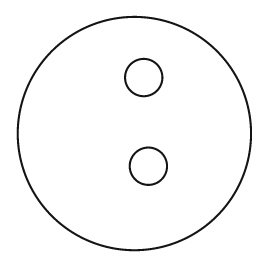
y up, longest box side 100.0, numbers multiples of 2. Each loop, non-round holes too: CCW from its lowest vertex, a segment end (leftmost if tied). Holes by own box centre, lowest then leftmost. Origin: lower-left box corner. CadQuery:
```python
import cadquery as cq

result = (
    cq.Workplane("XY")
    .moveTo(50.0, 50.0)
    .circle(50.0)
    .moveTo(56.0, 36.0)
    .circle(8.0)
    .moveTo(54.0, 74.0)
    .circle(8.0)
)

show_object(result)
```